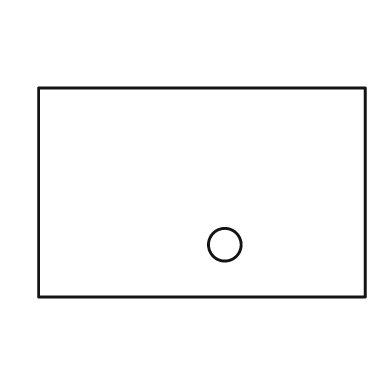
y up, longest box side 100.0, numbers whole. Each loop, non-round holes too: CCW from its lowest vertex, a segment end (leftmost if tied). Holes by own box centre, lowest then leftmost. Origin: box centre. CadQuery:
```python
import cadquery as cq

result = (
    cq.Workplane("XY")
    .moveTo(-50.0, -32.0)
    .lineTo(50.0, -32.0)
    .lineTo(50.0, 32.0)
    .lineTo(-50.0, 32.0)
    .close()
    .moveTo(7.0, -16.0)
    .circle(5.0)
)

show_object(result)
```